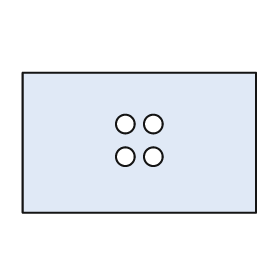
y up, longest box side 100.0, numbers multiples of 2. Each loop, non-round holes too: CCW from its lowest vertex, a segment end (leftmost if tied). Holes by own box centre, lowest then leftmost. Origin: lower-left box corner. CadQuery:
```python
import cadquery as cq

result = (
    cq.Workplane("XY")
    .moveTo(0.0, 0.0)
    .lineTo(100.0, 0.0)
    .lineTo(100.0, 60.0)
    .lineTo(0.0, 60.0)
    .close()
    .moveTo(44.0, 24.0)
    .circle(4.0)
    .moveTo(56.0, 24.0)
    .circle(4.0)
    .moveTo(44.0, 38.0)
    .circle(4.0)
    .moveTo(56.0, 38.0)
    .circle(4.0)
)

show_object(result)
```